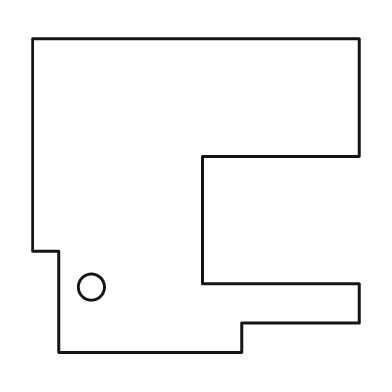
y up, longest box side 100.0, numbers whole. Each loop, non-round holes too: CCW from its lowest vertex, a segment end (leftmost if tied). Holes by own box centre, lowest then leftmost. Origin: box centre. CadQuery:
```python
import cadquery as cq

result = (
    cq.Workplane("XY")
    .moveTo(-42.0, -48.0)
    .lineTo(14.0, -48.0)
    .lineTo(14.0, -39.0)
    .lineTo(50.0, -39.0)
    .lineTo(50.0, -27.0)
    .lineTo(2.0, -27.0)
    .lineTo(2.0, 12.0)
    .lineTo(50.0, 12.0)
    .lineTo(50.0, 48.0)
    .lineTo(-50.0, 48.0)
    .lineTo(-50.0, -17.0)
    .lineTo(-42.0, -17.0)
    .close()
    .moveTo(-32.0, -28.0)
    .circle(4.0)
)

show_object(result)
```